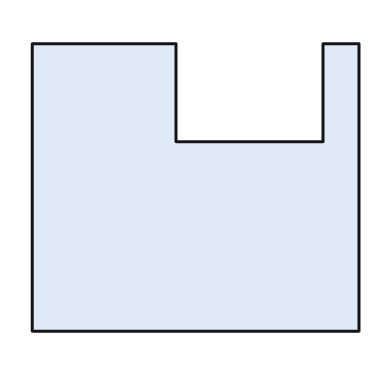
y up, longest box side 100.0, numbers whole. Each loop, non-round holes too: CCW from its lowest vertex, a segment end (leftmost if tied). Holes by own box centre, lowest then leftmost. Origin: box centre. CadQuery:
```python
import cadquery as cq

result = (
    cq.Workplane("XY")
    .moveTo(-50.0, -44.0)
    .lineTo(50.0, -44.0)
    .lineTo(50.0, 44.0)
    .lineTo(39.0, 44.0)
    .lineTo(39.0, 14.0)
    .lineTo(-6.0, 14.0)
    .lineTo(-6.0, 44.0)
    .lineTo(-50.0, 44.0)
    .close()
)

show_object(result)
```